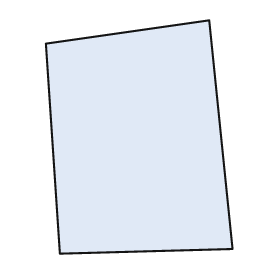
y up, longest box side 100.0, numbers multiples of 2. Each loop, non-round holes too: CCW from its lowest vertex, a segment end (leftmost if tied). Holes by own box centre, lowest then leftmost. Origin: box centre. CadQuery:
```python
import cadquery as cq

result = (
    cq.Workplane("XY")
    .moveTo(-34.0, -50.0)
    .lineTo(40.0, -48.0)
    .lineTo(30.0, 50.0)
    .lineTo(-40.0, 40.0)
    .close()
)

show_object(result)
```